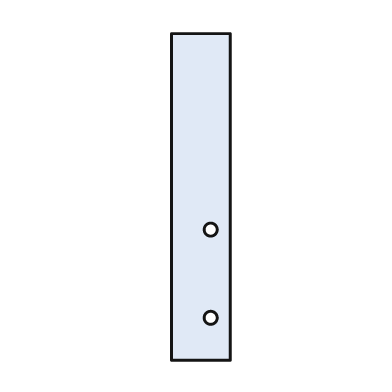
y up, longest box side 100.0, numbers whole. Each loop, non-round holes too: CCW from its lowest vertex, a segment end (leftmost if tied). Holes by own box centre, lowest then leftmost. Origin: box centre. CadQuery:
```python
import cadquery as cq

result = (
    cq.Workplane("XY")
    .moveTo(-9.0, -50.0)
    .lineTo(9.0, -50.0)
    .lineTo(9.0, 50.0)
    .lineTo(-9.0, 50.0)
    .close()
    .moveTo(3.0, -37.0)
    .circle(2.0)
    .moveTo(3.0, -10.0)
    .circle(2.0)
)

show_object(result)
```